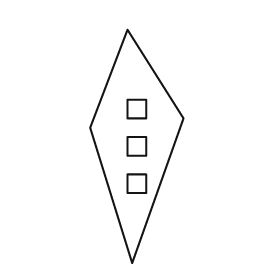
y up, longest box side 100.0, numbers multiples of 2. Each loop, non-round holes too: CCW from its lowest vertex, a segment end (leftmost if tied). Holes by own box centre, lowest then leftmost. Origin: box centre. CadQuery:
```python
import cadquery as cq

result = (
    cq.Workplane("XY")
    .moveTo(-2.0, -50.0)
    .lineTo(20.0, 12.0)
    .lineTo(-4.0, 50.0)
    .lineTo(-20.0, 8.0)
    .close()
    .moveTo(-4.0, -20.0)
    .lineTo(4.0, -20.0)
    .lineTo(4.0, -12.0)
    .lineTo(-4.0, -12.0)
    .close()
    .moveTo(-4.0, -4.0)
    .lineTo(4.0, -4.0)
    .lineTo(4.0, 4.0)
    .lineTo(-4.0, 4.0)
    .close()
    .moveTo(-4.0, 12.0)
    .lineTo(4.0, 12.0)
    .lineTo(4.0, 20.0)
    .lineTo(-4.0, 20.0)
    .close()
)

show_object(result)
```